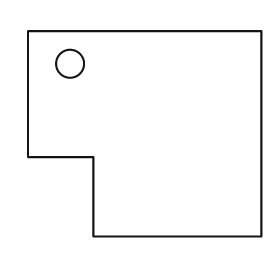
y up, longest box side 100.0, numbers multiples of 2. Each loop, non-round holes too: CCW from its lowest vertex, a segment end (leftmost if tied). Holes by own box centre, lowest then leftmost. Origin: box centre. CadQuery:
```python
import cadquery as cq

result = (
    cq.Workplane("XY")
    .moveTo(-22.0, -44.0)
    .lineTo(50.0, -44.0)
    .lineTo(50.0, 44.0)
    .lineTo(-50.0, 44.0)
    .lineTo(-50.0, -10.0)
    .lineTo(-22.0, -10.0)
    .close()
    .moveTo(-32.0, 30.0)
    .circle(6.0)
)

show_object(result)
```